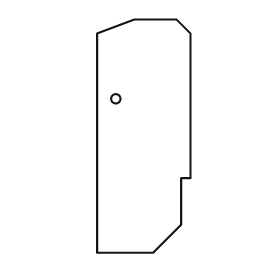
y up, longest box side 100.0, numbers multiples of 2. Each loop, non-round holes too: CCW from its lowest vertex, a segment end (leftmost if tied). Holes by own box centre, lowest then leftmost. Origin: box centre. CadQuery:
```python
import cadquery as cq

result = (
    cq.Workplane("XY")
    .moveTo(-20.0, -50.0)
    .lineTo(4.0, -50.0)
    .lineTo(16.0, -38.0)
    .lineTo(16.0, -18.0)
    .lineTo(20.0, -18.0)
    .lineTo(20.0, 44.0)
    .lineTo(14.0, 50.0)
    .lineTo(-4.0, 50.0)
    .lineTo(-20.0, 44.0)
    .close()
    .moveTo(-12.0, 16.0)
    .circle(2.0)
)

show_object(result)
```